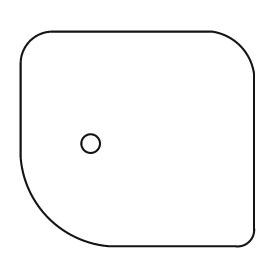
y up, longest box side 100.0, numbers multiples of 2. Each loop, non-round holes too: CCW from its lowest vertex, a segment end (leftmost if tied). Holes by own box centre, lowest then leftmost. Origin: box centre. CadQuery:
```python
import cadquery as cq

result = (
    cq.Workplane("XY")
    .moveTo(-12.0, -46.0)
    .lineTo(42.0, -46.0)
    .threePointArc((48.0, -44.0), (50.0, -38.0))
    .lineTo(50.0, 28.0)
    .threePointArc((44.0, 40.0), (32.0, 46.0))
    .lineTo(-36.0, 46.0)
    .threePointArc((-46.0, 42.0), (-50.0, 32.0))
    .lineTo(-50.0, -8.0)
    .threePointArc((-38.0, -34.0), (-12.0, -46.0))
    .close()
    .moveTo(-20.0, -2.0)
    .circle(4.0)
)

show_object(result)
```